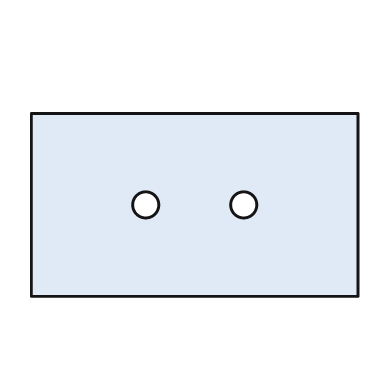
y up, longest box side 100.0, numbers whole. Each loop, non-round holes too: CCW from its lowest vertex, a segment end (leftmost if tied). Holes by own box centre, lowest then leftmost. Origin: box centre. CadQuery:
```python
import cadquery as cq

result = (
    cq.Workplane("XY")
    .moveTo(-50.0, -28.0)
    .lineTo(50.0, -28.0)
    .lineTo(50.0, 28.0)
    .lineTo(-50.0, 28.0)
    .close()
    .moveTo(-15.0, 0.0)
    .circle(4.0)
    .moveTo(15.0, 0.0)
    .circle(4.0)
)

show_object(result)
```